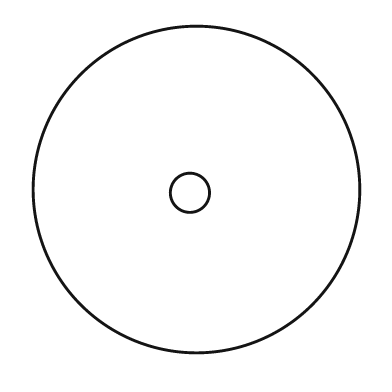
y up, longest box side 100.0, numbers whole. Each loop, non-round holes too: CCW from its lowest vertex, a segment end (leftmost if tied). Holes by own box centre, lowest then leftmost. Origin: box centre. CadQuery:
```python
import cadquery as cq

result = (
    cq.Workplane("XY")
    .moveTo(0.0, 0.0)
    .circle(50.0)
    .moveTo(-2.0, -1.0)
    .circle(6.0)
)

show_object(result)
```